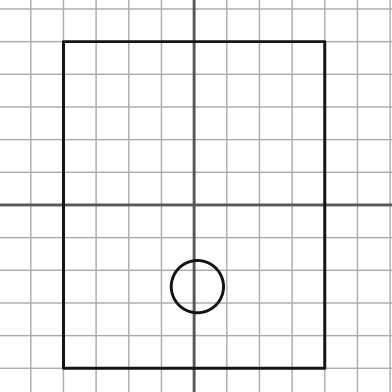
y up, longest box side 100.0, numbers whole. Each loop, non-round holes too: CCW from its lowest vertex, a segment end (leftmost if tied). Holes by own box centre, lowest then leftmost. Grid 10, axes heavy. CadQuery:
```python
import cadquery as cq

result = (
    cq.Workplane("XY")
    .moveTo(-40.0, -50.0)
    .lineTo(40.0, -50.0)
    .lineTo(40.0, 50.0)
    .lineTo(-40.0, 50.0)
    .close()
    .moveTo(1.0, -25.0)
    .circle(8.0)
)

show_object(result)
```